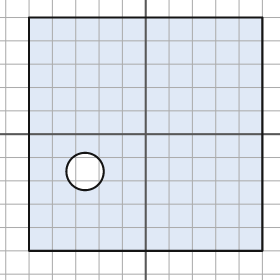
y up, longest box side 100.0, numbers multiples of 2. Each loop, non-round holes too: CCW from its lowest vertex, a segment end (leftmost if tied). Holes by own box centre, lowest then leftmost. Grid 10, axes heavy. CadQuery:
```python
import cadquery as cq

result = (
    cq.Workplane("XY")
    .moveTo(-50.0, -50.0)
    .lineTo(50.0, -50.0)
    .lineTo(50.0, 50.0)
    .lineTo(-50.0, 50.0)
    .close()
    .moveTo(-26.0, -16.0)
    .circle(8.0)
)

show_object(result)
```